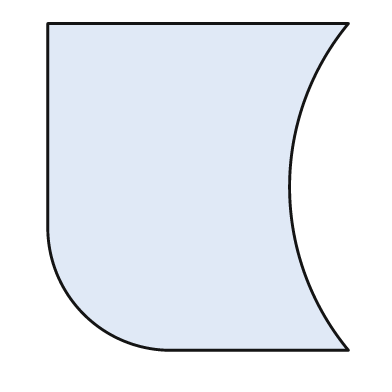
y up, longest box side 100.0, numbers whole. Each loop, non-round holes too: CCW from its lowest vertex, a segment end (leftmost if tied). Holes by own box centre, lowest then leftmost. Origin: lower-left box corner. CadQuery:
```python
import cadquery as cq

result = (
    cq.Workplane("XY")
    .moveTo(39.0, 0.0)
    .lineTo(92.0, 0.0)
    .threePointArc((74.0, 50.0), (92.0, 100.0))
    .lineTo(0.0, 100.0)
    .lineTo(0.0, 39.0)
    .threePointArc((11.0, 11.0), (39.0, 0.0))
    .close()
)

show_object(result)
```